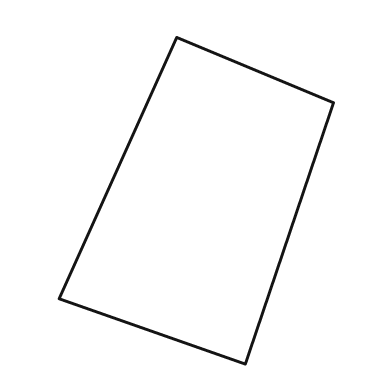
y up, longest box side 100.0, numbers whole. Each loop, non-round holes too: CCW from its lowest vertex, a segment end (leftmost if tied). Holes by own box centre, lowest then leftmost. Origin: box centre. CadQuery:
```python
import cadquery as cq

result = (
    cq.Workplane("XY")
    .moveTo(15.0, -50.0)
    .lineTo(42.0, 30.0)
    .lineTo(-6.0, 50.0)
    .lineTo(-42.0, -30.0)
    .close()
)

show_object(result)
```